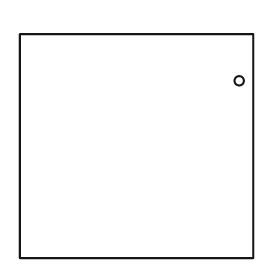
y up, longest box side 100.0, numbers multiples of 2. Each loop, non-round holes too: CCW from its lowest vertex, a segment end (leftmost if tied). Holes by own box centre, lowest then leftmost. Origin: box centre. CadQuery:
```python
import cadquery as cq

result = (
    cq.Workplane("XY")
    .moveTo(-50.0, -48.0)
    .lineTo(50.0, -48.0)
    .lineTo(50.0, 48.0)
    .lineTo(-50.0, 48.0)
    .close()
    .moveTo(44.0, 28.0)
    .circle(2.0)
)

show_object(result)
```